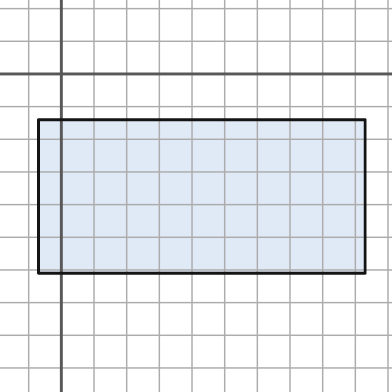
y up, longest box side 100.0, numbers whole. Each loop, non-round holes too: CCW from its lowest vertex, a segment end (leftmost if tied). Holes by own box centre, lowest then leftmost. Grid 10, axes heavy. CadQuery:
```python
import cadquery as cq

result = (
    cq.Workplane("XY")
    .moveTo(-7.0, -61.0)
    .lineTo(93.0, -61.0)
    .lineTo(93.0, -14.0)
    .lineTo(-7.0, -14.0)
    .close()
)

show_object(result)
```